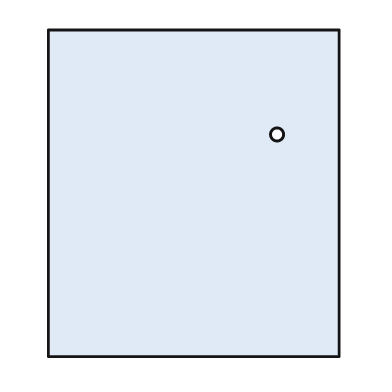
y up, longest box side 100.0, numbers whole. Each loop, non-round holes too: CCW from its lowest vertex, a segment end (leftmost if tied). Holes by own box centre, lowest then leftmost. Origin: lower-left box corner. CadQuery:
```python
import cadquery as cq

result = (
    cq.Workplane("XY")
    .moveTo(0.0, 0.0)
    .lineTo(89.0, 0.0)
    .lineTo(89.0, 100.0)
    .lineTo(0.0, 100.0)
    .close()
    .moveTo(70.0, 68.0)
    .circle(2.0)
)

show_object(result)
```